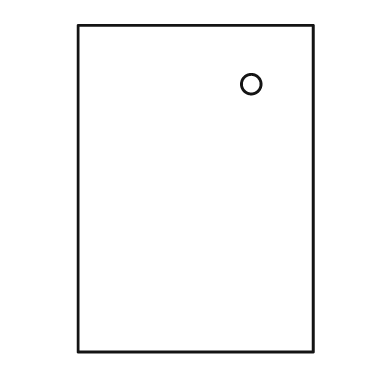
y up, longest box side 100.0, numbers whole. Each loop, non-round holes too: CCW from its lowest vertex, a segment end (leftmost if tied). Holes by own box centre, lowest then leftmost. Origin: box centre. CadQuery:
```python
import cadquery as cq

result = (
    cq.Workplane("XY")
    .moveTo(-36.0, -50.0)
    .lineTo(36.0, -50.0)
    .lineTo(36.0, 50.0)
    .lineTo(-36.0, 50.0)
    .close()
    .moveTo(17.0, 32.0)
    .circle(3.0)
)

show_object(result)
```